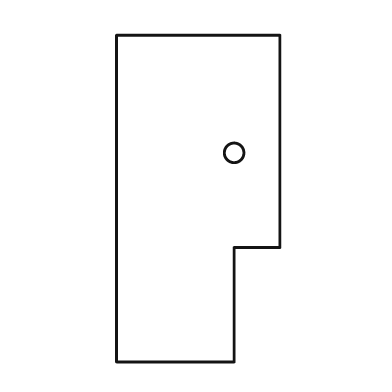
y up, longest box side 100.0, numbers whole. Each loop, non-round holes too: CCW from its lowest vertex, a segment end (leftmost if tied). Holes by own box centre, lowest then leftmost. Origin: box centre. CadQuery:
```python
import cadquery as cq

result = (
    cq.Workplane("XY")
    .moveTo(-25.0, -50.0)
    .lineTo(11.0, -50.0)
    .lineTo(11.0, -15.0)
    .lineTo(25.0, -15.0)
    .lineTo(25.0, 50.0)
    .lineTo(-25.0, 50.0)
    .close()
    .moveTo(11.0, 14.0)
    .circle(3.0)
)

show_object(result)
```